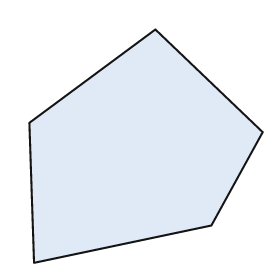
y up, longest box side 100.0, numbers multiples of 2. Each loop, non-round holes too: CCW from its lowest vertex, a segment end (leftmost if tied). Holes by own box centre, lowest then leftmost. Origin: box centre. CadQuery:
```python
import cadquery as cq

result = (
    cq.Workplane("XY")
    .moveTo(-48.0, -50.0)
    .lineTo(28.0, -34.0)
    .lineTo(50.0, 6.0)
    .lineTo(4.0, 50.0)
    .lineTo(-50.0, 10.0)
    .close()
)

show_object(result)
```